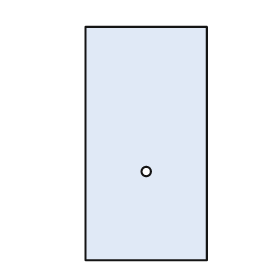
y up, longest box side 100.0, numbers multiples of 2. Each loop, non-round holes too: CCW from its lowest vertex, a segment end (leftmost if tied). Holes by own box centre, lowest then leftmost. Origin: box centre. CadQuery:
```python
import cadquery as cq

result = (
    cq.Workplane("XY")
    .moveTo(-26.0, -50.0)
    .lineTo(26.0, -50.0)
    .lineTo(26.0, 50.0)
    .lineTo(-26.0, 50.0)
    .close()
    .moveTo(0.0, -12.0)
    .circle(2.0)
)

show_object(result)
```